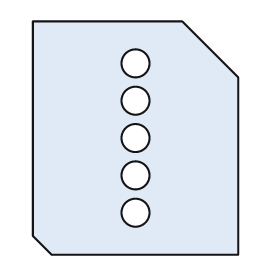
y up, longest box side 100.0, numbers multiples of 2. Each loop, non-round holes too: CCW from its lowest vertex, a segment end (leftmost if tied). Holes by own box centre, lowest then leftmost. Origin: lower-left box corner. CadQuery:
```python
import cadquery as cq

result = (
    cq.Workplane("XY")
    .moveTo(8.0, 0.0)
    .lineTo(88.0, 0.0)
    .lineTo(88.0, 76.0)
    .lineTo(64.0, 100.0)
    .lineTo(0.0, 100.0)
    .lineTo(0.0, 8.0)
    .close()
    .moveTo(44.0, 18.0)
    .circle(6.0)
    .moveTo(44.0, 34.0)
    .circle(6.0)
    .moveTo(44.0, 50.0)
    .circle(6.0)
    .moveTo(44.0, 66.0)
    .circle(6.0)
    .moveTo(44.0, 82.0)
    .circle(6.0)
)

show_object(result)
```